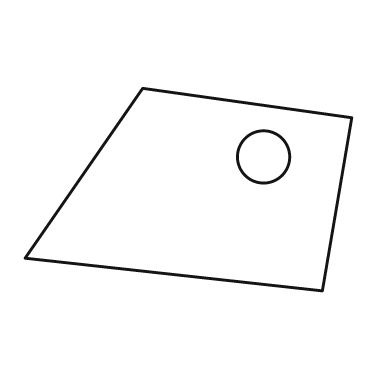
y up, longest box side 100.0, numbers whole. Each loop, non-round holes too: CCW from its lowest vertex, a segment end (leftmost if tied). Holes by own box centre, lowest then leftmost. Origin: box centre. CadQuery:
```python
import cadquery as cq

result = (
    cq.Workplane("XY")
    .moveTo(41.0, -31.0)
    .lineTo(50.0, 22.0)
    .lineTo(-14.0, 31.0)
    .lineTo(-50.0, -21.0)
    .close()
    .moveTo(23.0, 10.0)
    .circle(8.0)
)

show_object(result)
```